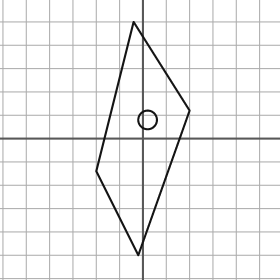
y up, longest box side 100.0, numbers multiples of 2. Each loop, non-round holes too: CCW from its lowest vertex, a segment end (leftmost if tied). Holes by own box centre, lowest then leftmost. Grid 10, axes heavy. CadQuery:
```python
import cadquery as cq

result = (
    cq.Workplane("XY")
    .moveTo(-2.0, -50.0)
    .lineTo(20.0, 12.0)
    .lineTo(-4.0, 50.0)
    .lineTo(-20.0, -14.0)
    .close()
    .moveTo(2.0, 8.0)
    .circle(4.0)
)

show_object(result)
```